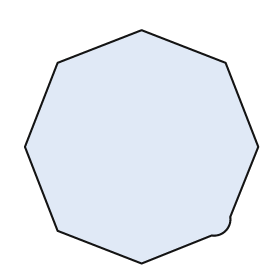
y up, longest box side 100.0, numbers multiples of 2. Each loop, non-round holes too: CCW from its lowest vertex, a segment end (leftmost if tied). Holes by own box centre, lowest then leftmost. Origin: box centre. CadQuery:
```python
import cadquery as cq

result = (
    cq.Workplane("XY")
    .moveTo(0.0, -50.0)
    .lineTo(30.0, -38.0)
    .threePointArc((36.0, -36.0), (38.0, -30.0))
    .lineTo(50.0, 0.0)
    .lineTo(36.0, 36.0)
    .lineTo(0.0, 50.0)
    .lineTo(-36.0, 36.0)
    .lineTo(-50.0, 0.0)
    .lineTo(-36.0, -36.0)
    .close()
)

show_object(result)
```